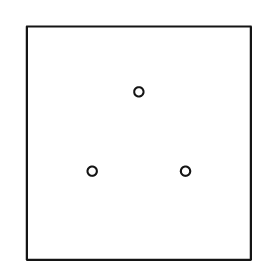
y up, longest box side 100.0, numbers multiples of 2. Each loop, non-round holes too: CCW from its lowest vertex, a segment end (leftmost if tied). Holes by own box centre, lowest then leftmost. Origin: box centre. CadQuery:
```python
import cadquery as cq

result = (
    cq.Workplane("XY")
    .moveTo(-48.0, -50.0)
    .lineTo(48.0, -50.0)
    .lineTo(48.0, 50.0)
    .lineTo(-48.0, 50.0)
    .close()
    .moveTo(-20.0, -12.0)
    .circle(2.0)
    .moveTo(20.0, -12.0)
    .circle(2.0)
    .moveTo(0.0, 22.0)
    .circle(2.0)
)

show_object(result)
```